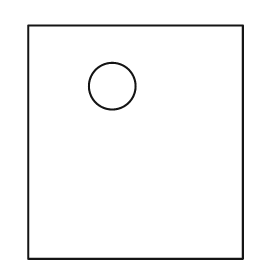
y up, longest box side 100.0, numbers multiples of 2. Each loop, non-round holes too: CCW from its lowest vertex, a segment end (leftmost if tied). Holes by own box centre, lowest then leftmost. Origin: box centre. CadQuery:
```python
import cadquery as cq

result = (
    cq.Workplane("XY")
    .moveTo(-46.0, -50.0)
    .lineTo(46.0, -50.0)
    .lineTo(46.0, 50.0)
    .lineTo(-46.0, 50.0)
    .close()
    .moveTo(-10.0, 24.0)
    .circle(10.0)
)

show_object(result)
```